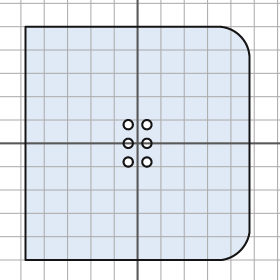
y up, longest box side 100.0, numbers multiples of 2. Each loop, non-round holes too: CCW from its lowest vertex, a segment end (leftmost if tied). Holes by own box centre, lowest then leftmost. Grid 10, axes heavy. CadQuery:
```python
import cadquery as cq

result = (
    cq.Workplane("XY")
    .moveTo(-48.0, -50.0)
    .lineTo(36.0, -50.0)
    .threePointArc((44.0, -46.0), (48.0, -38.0))
    .lineTo(48.0, 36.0)
    .threePointArc((44.0, 46.0), (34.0, 50.0))
    .lineTo(-48.0, 50.0)
    .close()
    .moveTo(-4.0, -8.0)
    .circle(2.0)
    .moveTo(4.0, -8.0)
    .circle(2.0)
    .moveTo(-4.0, 0.0)
    .circle(2.0)
    .moveTo(4.0, 0.0)
    .circle(2.0)
    .moveTo(-4.0, 8.0)
    .circle(2.0)
    .moveTo(4.0, 8.0)
    .circle(2.0)
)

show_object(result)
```